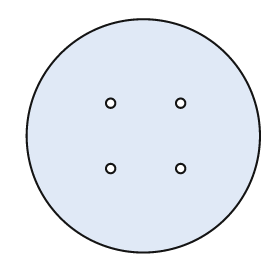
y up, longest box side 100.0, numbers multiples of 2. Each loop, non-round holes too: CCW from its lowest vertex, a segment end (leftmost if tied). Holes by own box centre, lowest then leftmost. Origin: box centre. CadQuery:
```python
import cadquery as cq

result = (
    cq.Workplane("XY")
    .moveTo(0.0, 0.0)
    .circle(50.0)
    .moveTo(-14.0, -14.0)
    .circle(2.0)
    .moveTo(16.0, -14.0)
    .circle(2.0)
    .moveTo(-14.0, 14.0)
    .circle(2.0)
    .moveTo(16.0, 14.0)
    .circle(2.0)
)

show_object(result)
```